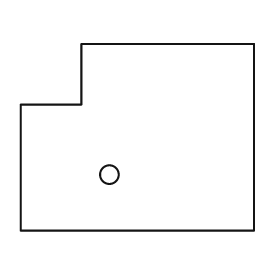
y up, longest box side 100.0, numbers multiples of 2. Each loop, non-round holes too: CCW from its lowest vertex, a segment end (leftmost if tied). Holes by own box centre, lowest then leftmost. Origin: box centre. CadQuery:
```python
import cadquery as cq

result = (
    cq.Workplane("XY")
    .moveTo(-50.0, -40.0)
    .lineTo(50.0, -40.0)
    .lineTo(50.0, 40.0)
    .lineTo(-24.0, 40.0)
    .lineTo(-24.0, 14.0)
    .lineTo(-50.0, 14.0)
    .close()
    .moveTo(-12.0, -16.0)
    .circle(4.0)
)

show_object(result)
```